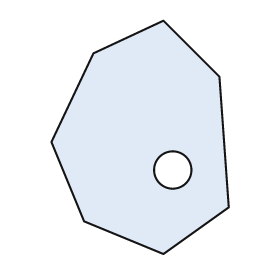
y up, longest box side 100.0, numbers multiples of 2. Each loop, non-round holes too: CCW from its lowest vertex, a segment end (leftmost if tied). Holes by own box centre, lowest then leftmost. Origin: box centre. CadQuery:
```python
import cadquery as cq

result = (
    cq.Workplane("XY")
    .moveTo(10.0, -50.0)
    .lineTo(38.0, -30.0)
    .lineTo(34.0, 26.0)
    .lineTo(10.0, 50.0)
    .lineTo(-20.0, 36.0)
    .lineTo(-38.0, -2.0)
    .lineTo(-24.0, -36.0)
    .close()
    .moveTo(14.0, -14.0)
    .circle(8.0)
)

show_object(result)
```